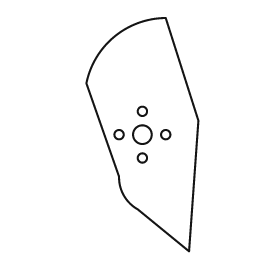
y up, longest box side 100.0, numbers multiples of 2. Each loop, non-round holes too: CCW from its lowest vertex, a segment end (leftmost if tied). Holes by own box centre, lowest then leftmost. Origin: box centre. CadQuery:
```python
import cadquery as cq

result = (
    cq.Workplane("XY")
    .moveTo(20.0, -50.0)
    .lineTo(24.0, 6.0)
    .lineTo(10.0, 50.0)
    .threePointArc((-12.0, 42.0), (-24.0, 22.0))
    .lineTo(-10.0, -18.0)
    .threePointArc((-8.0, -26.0), (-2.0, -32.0))
    .close()
    .moveTo(0.0, -10.0)
    .circle(2.0)
    .moveTo(-10.0, 0.0)
    .circle(2.0)
    .moveTo(0.0, 0.0)
    .circle(4.0)
    .moveTo(10.0, 0.0)
    .circle(2.0)
    .moveTo(0.0, 10.0)
    .circle(2.0)
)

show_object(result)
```